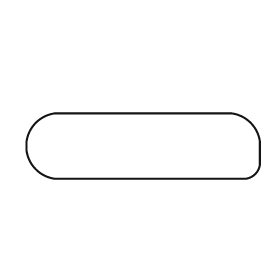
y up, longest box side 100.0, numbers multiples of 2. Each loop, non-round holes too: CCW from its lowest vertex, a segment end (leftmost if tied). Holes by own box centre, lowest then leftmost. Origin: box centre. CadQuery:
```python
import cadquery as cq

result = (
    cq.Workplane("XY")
    .moveTo(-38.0, -14.0)
    .lineTo(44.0, -14.0)
    .threePointArc((48.0, -12.0), (50.0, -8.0))
    .lineTo(50.0, 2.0)
    .threePointArc((46.0, 10.0), (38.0, 14.0))
    .lineTo(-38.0, 14.0)
    .threePointArc((-46.0, 10.0), (-50.0, 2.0))
    .lineTo(-50.0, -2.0)
    .threePointArc((-46.0, -10.0), (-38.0, -14.0))
    .close()
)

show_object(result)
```